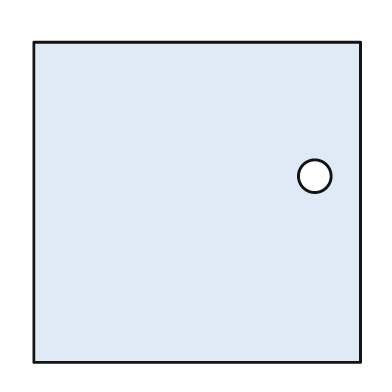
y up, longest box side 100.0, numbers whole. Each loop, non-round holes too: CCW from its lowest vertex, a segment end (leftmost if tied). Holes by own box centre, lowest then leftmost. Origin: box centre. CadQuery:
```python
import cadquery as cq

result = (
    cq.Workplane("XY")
    .moveTo(-50.0, -49.0)
    .lineTo(50.0, -49.0)
    .lineTo(50.0, 49.0)
    .lineTo(-50.0, 49.0)
    .close()
    .moveTo(36.0, 8.0)
    .circle(5.0)
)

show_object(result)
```